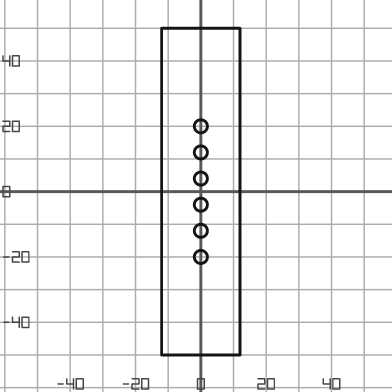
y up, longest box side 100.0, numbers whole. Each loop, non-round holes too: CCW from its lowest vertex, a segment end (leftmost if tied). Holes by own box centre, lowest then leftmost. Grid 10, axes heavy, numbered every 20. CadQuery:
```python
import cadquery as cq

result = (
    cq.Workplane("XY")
    .moveTo(-12.0, -50.0)
    .lineTo(12.0, -50.0)
    .lineTo(12.0, 50.0)
    .lineTo(-12.0, 50.0)
    .close()
    .moveTo(0.0, -20.0)
    .circle(2.0)
    .moveTo(0.0, -12.0)
    .circle(2.0)
    .moveTo(0.0, -4.0)
    .circle(2.0)
    .moveTo(0.0, 4.0)
    .circle(2.0)
    .moveTo(0.0, 12.0)
    .circle(2.0)
    .moveTo(0.0, 20.0)
    .circle(2.0)
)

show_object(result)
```